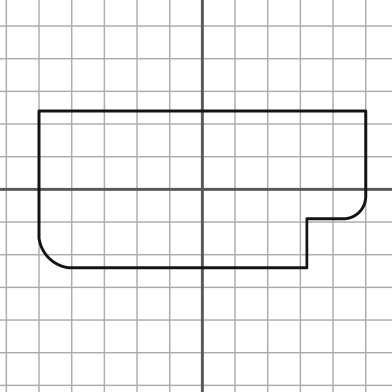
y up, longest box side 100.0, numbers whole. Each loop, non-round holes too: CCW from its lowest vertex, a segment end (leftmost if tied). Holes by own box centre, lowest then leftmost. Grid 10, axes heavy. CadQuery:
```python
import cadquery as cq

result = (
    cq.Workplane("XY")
    .moveTo(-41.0, -24.0)
    .lineTo(32.0, -24.0)
    .lineTo(32.0, -9.0)
    .lineTo(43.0, -9.0)
    .threePointArc((48.0, -7.0), (50.0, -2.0))
    .lineTo(50.0, 24.0)
    .lineTo(-50.0, 24.0)
    .lineTo(-50.0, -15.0)
    .threePointArc((-47.0, -21.0), (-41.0, -24.0))
    .close()
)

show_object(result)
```